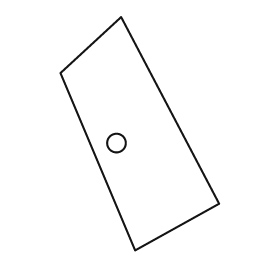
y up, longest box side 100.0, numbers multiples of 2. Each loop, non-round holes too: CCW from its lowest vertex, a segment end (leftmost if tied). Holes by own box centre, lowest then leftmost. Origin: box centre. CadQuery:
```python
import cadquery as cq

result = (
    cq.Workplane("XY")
    .moveTo(-2.0, -50.0)
    .lineTo(34.0, -30.0)
    .lineTo(-8.0, 50.0)
    .lineTo(-34.0, 26.0)
    .close()
    .moveTo(-10.0, -4.0)
    .circle(4.0)
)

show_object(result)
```